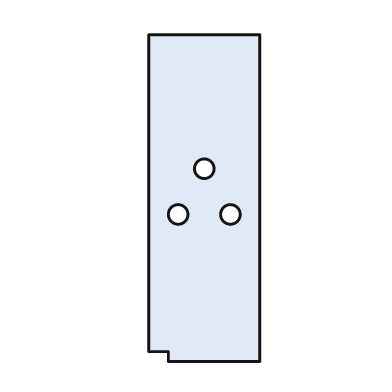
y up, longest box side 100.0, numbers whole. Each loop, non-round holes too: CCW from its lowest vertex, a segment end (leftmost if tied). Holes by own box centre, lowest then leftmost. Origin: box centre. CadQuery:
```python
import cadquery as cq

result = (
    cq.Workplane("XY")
    .moveTo(-11.0, -50.0)
    .lineTo(17.0, -50.0)
    .lineTo(17.0, 50.0)
    .lineTo(-17.0, 50.0)
    .lineTo(-17.0, -47.0)
    .lineTo(-11.0, -47.0)
    .close()
    .moveTo(-8.0, -5.0)
    .circle(3.0)
    .moveTo(8.0, -5.0)
    .circle(3.0)
    .moveTo(0.0, 9.0)
    .circle(3.0)
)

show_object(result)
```